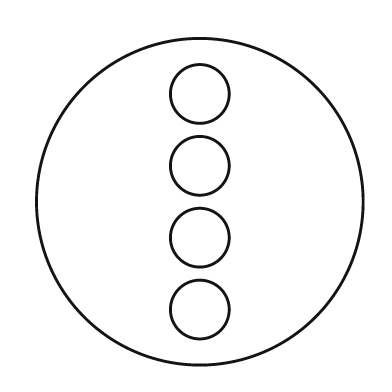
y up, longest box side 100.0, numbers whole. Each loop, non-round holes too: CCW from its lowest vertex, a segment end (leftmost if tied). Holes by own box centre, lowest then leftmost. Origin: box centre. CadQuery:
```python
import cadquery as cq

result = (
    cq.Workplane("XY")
    .moveTo(0.0, 0.0)
    .circle(50.0)
    .moveTo(0.0, -33.0)
    .circle(9.0)
    .moveTo(0.0, -11.0)
    .circle(9.0)
    .moveTo(0.0, 11.0)
    .circle(9.0)
    .moveTo(0.0, 33.0)
    .circle(9.0)
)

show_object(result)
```